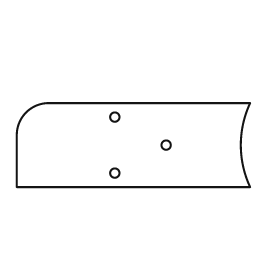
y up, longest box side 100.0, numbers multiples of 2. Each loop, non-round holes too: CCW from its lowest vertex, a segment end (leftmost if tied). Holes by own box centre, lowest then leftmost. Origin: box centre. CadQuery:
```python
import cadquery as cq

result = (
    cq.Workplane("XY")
    .moveTo(-50.0, -18.0)
    .lineTo(50.0, -18.0)
    .threePointArc((46.0, 0.0), (50.0, 18.0))
    .lineTo(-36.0, 18.0)
    .threePointArc((-46.0, 14.0), (-50.0, 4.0))
    .close()
    .moveTo(-8.0, -12.0)
    .circle(2.0)
    .moveTo(14.0, 0.0)
    .circle(2.0)
    .moveTo(-8.0, 12.0)
    .circle(2.0)
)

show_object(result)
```